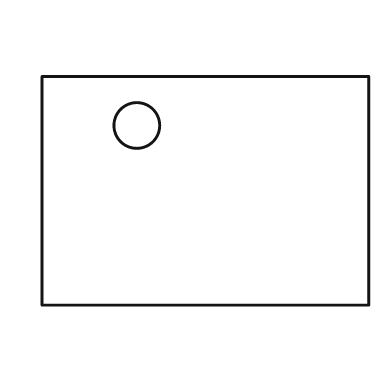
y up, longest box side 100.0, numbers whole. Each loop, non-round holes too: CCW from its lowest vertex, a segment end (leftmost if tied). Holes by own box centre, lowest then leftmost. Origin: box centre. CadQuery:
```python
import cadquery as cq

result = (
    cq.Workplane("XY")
    .moveTo(-50.0, -35.0)
    .lineTo(50.0, -35.0)
    .lineTo(50.0, 35.0)
    .lineTo(-50.0, 35.0)
    .close()
    .moveTo(-21.0, 20.0)
    .circle(7.0)
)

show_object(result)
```